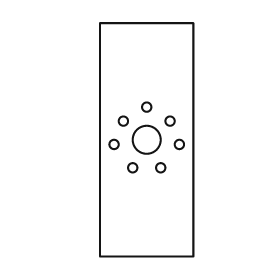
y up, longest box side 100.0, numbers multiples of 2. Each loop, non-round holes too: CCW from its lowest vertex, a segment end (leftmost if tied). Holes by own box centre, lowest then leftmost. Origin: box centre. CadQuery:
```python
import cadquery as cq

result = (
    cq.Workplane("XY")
    .moveTo(-20.0, -50.0)
    .lineTo(20.0, -50.0)
    .lineTo(20.0, 50.0)
    .lineTo(-20.0, 50.0)
    .close()
    .moveTo(-6.0, -12.0)
    .circle(2.0)
    .moveTo(6.0, -12.0)
    .circle(2.0)
    .moveTo(-14.0, -2.0)
    .circle(2.0)
    .moveTo(14.0, -2.0)
    .circle(2.0)
    .moveTo(0.0, 0.0)
    .circle(6.0)
    .moveTo(-10.0, 8.0)
    .circle(2.0)
    .moveTo(10.0, 8.0)
    .circle(2.0)
    .moveTo(0.0, 14.0)
    .circle(2.0)
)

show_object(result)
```